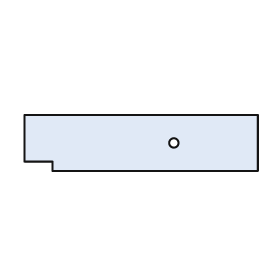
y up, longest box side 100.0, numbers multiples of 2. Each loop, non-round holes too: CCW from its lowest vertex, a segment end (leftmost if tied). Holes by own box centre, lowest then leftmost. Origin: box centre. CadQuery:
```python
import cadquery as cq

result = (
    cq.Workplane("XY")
    .moveTo(-38.0, -12.0)
    .lineTo(50.0, -12.0)
    .lineTo(50.0, 12.0)
    .lineTo(-50.0, 12.0)
    .lineTo(-50.0, -8.0)
    .lineTo(-38.0, -8.0)
    .close()
    .moveTo(14.0, 0.0)
    .circle(2.0)
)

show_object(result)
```